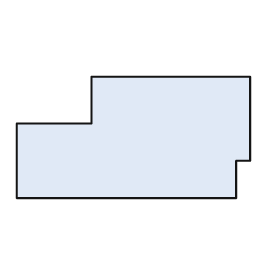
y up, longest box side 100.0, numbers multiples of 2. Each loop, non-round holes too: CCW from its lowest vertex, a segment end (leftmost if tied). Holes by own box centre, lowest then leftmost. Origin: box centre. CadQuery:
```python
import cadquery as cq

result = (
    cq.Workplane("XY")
    .moveTo(-50.0, -26.0)
    .lineTo(44.0, -26.0)
    .lineTo(44.0, -10.0)
    .lineTo(50.0, -10.0)
    .lineTo(50.0, 26.0)
    .lineTo(-18.0, 26.0)
    .lineTo(-18.0, 6.0)
    .lineTo(-50.0, 6.0)
    .close()
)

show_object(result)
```